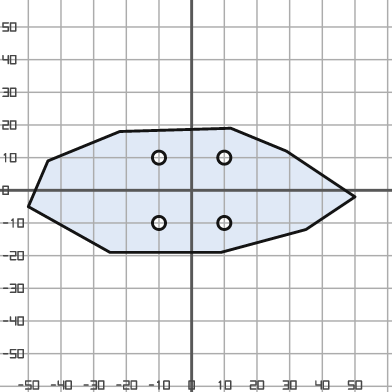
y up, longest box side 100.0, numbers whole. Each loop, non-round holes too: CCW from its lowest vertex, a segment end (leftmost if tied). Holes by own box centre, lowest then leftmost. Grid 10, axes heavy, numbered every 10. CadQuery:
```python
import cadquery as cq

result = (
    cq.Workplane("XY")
    .moveTo(-25.0, -19.0)
    .lineTo(9.0, -19.0)
    .lineTo(35.0, -12.0)
    .lineTo(50.0, -2.0)
    .lineTo(29.0, 12.0)
    .lineTo(12.0, 19.0)
    .lineTo(-22.0, 18.0)
    .lineTo(-44.0, 9.0)
    .lineTo(-50.0, -5.0)
    .close()
    .moveTo(-10.0, -10.0)
    .circle(2.0)
    .moveTo(10.0, -10.0)
    .circle(2.0)
    .moveTo(-10.0, 10.0)
    .circle(2.0)
    .moveTo(10.0, 10.0)
    .circle(2.0)
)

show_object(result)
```